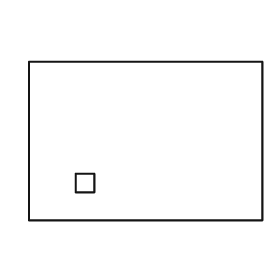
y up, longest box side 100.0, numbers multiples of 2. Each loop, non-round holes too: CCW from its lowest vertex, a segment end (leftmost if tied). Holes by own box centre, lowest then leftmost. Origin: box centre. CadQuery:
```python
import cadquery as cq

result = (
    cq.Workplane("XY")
    .moveTo(-50.0, -34.0)
    .lineTo(50.0, -34.0)
    .lineTo(50.0, 34.0)
    .lineTo(-50.0, 34.0)
    .close()
    .moveTo(-30.0, -22.0)
    .lineTo(-22.0, -22.0)
    .lineTo(-22.0, -14.0)
    .lineTo(-30.0, -14.0)
    .close()
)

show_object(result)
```